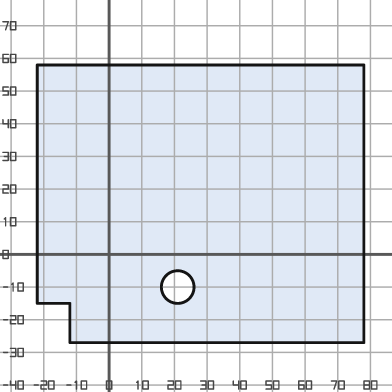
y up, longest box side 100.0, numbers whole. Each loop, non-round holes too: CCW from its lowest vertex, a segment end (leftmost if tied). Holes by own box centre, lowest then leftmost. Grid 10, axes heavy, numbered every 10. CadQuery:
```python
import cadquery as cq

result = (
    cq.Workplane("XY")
    .moveTo(-12.0, -27.0)
    .lineTo(78.0, -27.0)
    .lineTo(78.0, 58.0)
    .lineTo(-22.0, 58.0)
    .lineTo(-22.0, -15.0)
    .lineTo(-12.0, -15.0)
    .close()
    .moveTo(21.0, -10.0)
    .circle(5.0)
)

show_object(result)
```